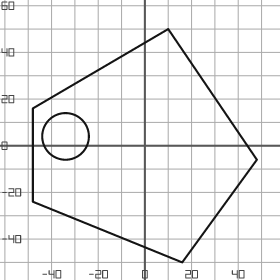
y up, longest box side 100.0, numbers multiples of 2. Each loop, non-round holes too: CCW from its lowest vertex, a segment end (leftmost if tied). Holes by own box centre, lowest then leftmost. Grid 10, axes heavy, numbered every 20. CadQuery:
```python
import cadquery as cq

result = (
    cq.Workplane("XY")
    .moveTo(16.0, -50.0)
    .lineTo(48.0, -6.0)
    .lineTo(10.0, 50.0)
    .lineTo(-48.0, 16.0)
    .lineTo(-48.0, -24.0)
    .close()
    .moveTo(-34.0, 4.0)
    .circle(10.0)
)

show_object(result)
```